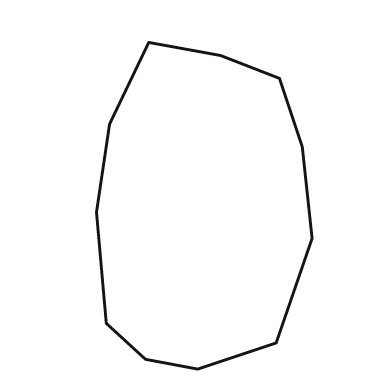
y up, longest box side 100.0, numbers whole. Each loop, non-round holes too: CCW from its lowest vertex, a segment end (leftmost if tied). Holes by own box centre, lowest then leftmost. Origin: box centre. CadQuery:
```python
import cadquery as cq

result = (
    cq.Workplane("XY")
    .moveTo(-2.0, -50.0)
    .lineTo(22.0, -42.0)
    .lineTo(33.0, -10.0)
    .lineTo(30.0, 18.0)
    .lineTo(23.0, 39.0)
    .lineTo(5.0, 46.0)
    .lineTo(-17.0, 50.0)
    .lineTo(-29.0, 25.0)
    .lineTo(-33.0, -2.0)
    .lineTo(-30.0, -36.0)
    .lineTo(-18.0, -47.0)
    .close()
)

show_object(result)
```